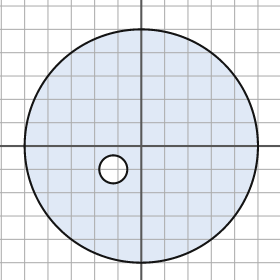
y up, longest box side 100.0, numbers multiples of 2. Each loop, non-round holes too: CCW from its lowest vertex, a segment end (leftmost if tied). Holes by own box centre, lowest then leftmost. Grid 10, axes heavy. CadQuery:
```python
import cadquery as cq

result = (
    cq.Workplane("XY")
    .moveTo(0.0, 0.0)
    .circle(50.0)
    .moveTo(-12.0, -10.0)
    .circle(6.0)
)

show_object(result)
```